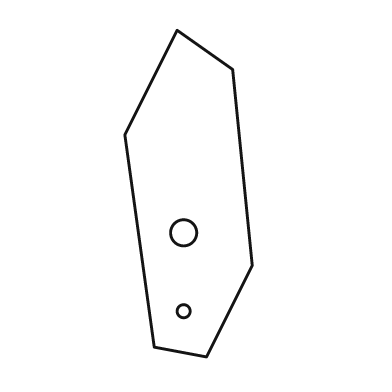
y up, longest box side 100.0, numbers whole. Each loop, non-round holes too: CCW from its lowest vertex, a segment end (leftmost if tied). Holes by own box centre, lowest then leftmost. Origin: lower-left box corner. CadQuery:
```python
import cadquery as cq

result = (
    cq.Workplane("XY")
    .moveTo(25.0, 0.0)
    .lineTo(39.0, 28.0)
    .lineTo(33.0, 88.0)
    .lineTo(16.0, 100.0)
    .lineTo(0.0, 68.0)
    .lineTo(9.0, 3.0)
    .close()
    .moveTo(18.0, 14.0)
    .circle(2.0)
    .moveTo(18.0, 38.0)
    .circle(4.0)
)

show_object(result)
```